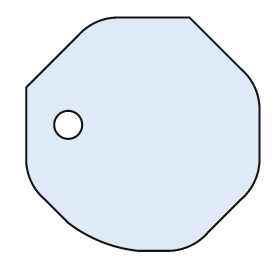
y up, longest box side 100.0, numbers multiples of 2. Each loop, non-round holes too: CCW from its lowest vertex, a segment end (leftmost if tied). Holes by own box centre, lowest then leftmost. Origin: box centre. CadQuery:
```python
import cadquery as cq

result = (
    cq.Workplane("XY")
    .moveTo(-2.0, -50.0)
    .lineTo(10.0, -50.0)
    .threePointArc((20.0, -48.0), (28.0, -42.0))
    .lineTo(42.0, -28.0)
    .threePointArc((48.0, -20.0), (50.0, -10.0))
    .lineTo(50.0, 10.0)
    .threePointArc((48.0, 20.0), (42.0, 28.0))
    .lineTo(20.0, 50.0)
    .lineTo(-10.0, 50.0)
    .threePointArc((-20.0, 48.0), (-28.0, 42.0))
    .lineTo(-50.0, 20.0)
    .lineTo(-50.0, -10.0)
    .threePointArc((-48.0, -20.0), (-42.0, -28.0))
    .lineTo(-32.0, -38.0)
    .threePointArc((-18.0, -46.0), (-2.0, -50.0))
    .close()
    .moveTo(-32.0, 4.0)
    .circle(6.0)
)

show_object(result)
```